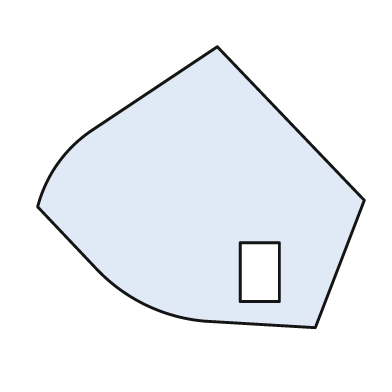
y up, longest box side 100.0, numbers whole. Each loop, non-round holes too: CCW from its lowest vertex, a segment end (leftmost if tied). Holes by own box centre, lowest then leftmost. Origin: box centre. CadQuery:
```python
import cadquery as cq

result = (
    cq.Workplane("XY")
    .moveTo(35.0, -43.0)
    .lineTo(50.0, -4.0)
    .lineTo(5.0, 43.0)
    .lineTo(-34.0, 17.0)
    .threePointArc((-44.0, 7.0), (-50.0, -6.0))
    .lineTo(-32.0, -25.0)
    .threePointArc((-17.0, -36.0), (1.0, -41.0))
    .close()
    .moveTo(12.0, -35.0)
    .lineTo(24.0, -35.0)
    .lineTo(24.0, -17.0)
    .lineTo(12.0, -17.0)
    .close()
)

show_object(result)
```